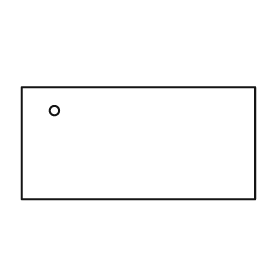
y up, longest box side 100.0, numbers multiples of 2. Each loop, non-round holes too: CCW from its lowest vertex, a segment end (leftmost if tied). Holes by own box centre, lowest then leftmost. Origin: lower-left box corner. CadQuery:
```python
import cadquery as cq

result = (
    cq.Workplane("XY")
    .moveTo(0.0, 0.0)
    .lineTo(100.0, 0.0)
    .lineTo(100.0, 48.0)
    .lineTo(0.0, 48.0)
    .close()
    .moveTo(14.0, 38.0)
    .circle(2.0)
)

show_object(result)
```